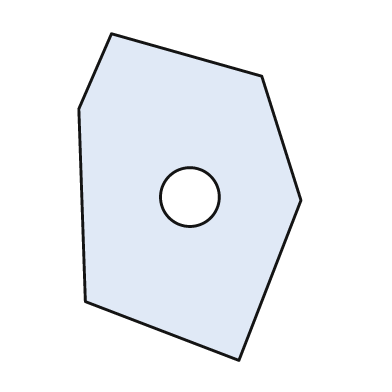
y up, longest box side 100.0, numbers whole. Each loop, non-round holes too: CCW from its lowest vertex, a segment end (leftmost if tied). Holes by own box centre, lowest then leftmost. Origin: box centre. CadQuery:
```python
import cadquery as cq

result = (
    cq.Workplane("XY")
    .moveTo(15.0, -50.0)
    .lineTo(34.0, -1.0)
    .lineTo(22.0, 37.0)
    .lineTo(-24.0, 50.0)
    .lineTo(-34.0, 27.0)
    .lineTo(-32.0, -32.0)
    .close()
    .moveTo(0.0, 0.0)
    .circle(9.0)
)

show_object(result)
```